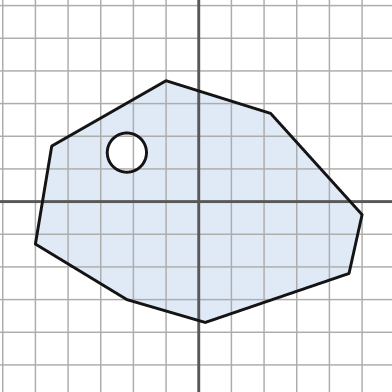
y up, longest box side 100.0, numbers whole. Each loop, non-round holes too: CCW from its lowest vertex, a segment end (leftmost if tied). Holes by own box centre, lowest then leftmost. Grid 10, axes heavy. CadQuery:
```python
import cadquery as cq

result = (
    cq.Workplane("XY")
    .moveTo(2.0, -37.0)
    .lineTo(46.0, -22.0)
    .lineTo(50.0, -4.0)
    .lineTo(22.0, 27.0)
    .lineTo(-10.0, 37.0)
    .lineTo(-45.0, 17.0)
    .lineTo(-50.0, -13.0)
    .lineTo(-22.0, -30.0)
    .close()
    .moveTo(-22.0, 15.0)
    .circle(6.0)
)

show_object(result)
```